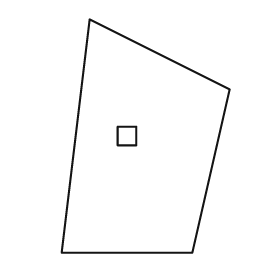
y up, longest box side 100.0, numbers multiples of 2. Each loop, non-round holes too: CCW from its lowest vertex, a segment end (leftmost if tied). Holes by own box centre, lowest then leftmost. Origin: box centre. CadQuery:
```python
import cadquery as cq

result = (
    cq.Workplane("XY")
    .moveTo(-36.0, -50.0)
    .lineTo(20.0, -50.0)
    .lineTo(36.0, 20.0)
    .lineTo(-24.0, 50.0)
    .close()
    .moveTo(-12.0, -4.0)
    .lineTo(-4.0, -4.0)
    .lineTo(-4.0, 4.0)
    .lineTo(-12.0, 4.0)
    .close()
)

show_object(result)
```